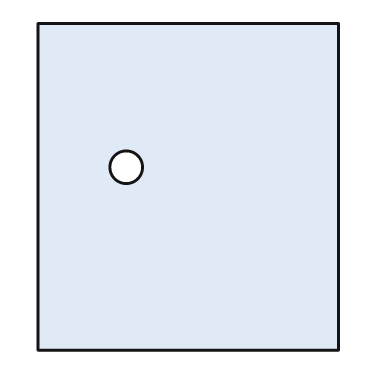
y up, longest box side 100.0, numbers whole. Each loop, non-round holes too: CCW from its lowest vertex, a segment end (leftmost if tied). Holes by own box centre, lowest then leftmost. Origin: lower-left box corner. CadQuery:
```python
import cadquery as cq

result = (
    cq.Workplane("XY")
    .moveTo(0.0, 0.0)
    .lineTo(92.0, 0.0)
    .lineTo(92.0, 100.0)
    .lineTo(0.0, 100.0)
    .close()
    .moveTo(27.0, 56.0)
    .circle(5.0)
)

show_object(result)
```